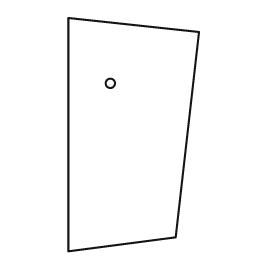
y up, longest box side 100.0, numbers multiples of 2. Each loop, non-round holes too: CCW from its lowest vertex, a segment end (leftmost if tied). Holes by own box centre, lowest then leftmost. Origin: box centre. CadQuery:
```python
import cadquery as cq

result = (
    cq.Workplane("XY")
    .moveTo(-28.0, -50.0)
    .lineTo(18.0, -44.0)
    .lineTo(28.0, 44.0)
    .lineTo(-28.0, 50.0)
    .close()
    .moveTo(-10.0, 22.0)
    .circle(2.0)
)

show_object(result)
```